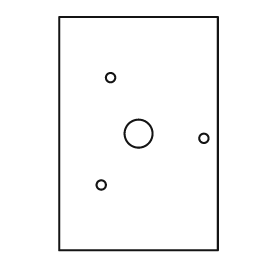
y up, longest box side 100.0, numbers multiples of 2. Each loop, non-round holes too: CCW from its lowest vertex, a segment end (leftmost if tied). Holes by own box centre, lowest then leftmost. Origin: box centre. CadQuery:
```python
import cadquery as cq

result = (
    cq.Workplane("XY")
    .moveTo(-34.0, -50.0)
    .lineTo(34.0, -50.0)
    .lineTo(34.0, 50.0)
    .lineTo(-34.0, 50.0)
    .close()
    .moveTo(-16.0, -22.0)
    .circle(2.0)
    .moveTo(28.0, -2.0)
    .circle(2.0)
    .moveTo(0.0, 0.0)
    .circle(6.0)
    .moveTo(-12.0, 24.0)
    .circle(2.0)
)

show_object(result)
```